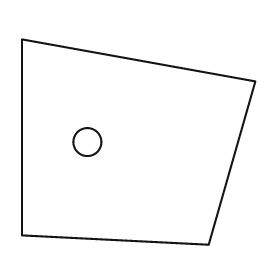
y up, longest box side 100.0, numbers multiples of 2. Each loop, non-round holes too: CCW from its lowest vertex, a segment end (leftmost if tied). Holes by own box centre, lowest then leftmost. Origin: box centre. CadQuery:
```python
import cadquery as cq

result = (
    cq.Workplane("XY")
    .moveTo(30.0, -44.0)
    .lineTo(50.0, 26.0)
    .lineTo(-50.0, 44.0)
    .lineTo(-50.0, -40.0)
    .close()
    .moveTo(-22.0, 0.0)
    .circle(6.0)
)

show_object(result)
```